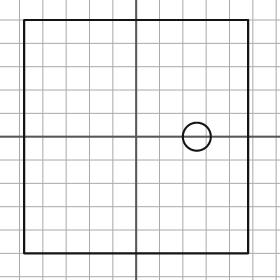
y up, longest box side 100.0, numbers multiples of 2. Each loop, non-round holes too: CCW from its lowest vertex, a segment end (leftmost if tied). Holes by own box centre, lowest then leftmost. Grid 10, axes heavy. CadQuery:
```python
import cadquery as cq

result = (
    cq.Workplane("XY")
    .moveTo(-48.0, -50.0)
    .lineTo(48.0, -50.0)
    .lineTo(48.0, 50.0)
    .lineTo(-48.0, 50.0)
    .close()
    .moveTo(26.0, 0.0)
    .circle(6.0)
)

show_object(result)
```